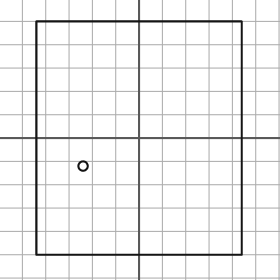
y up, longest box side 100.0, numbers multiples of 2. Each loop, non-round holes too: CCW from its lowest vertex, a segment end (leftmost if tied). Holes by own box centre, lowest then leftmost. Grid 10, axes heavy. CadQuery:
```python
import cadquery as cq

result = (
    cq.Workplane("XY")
    .moveTo(-44.0, -50.0)
    .lineTo(44.0, -50.0)
    .lineTo(44.0, 50.0)
    .lineTo(-44.0, 50.0)
    .close()
    .moveTo(-24.0, -12.0)
    .circle(2.0)
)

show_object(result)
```